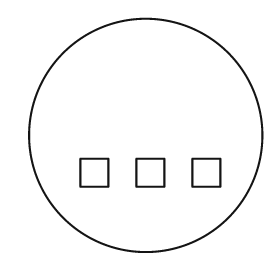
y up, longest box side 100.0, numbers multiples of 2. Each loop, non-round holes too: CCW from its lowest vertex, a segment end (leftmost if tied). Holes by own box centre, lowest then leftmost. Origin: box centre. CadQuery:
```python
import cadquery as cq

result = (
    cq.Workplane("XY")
    .moveTo(0.0, 0.0)
    .circle(50.0)
    .moveTo(-28.0, -22.0)
    .lineTo(-16.0, -22.0)
    .lineTo(-16.0, -10.0)
    .lineTo(-28.0, -10.0)
    .close()
    .moveTo(-4.0, -22.0)
    .lineTo(8.0, -22.0)
    .lineTo(8.0, -10.0)
    .lineTo(-4.0, -10.0)
    .close()
    .moveTo(20.0, -22.0)
    .lineTo(32.0, -22.0)
    .lineTo(32.0, -10.0)
    .lineTo(20.0, -10.0)
    .close()
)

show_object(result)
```